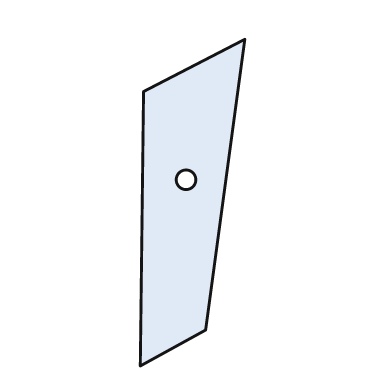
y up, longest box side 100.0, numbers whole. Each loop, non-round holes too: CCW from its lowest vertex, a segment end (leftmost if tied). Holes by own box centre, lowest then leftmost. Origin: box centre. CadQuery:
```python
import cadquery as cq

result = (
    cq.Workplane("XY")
    .moveTo(-16.0, -50.0)
    .lineTo(4.0, -39.0)
    .lineTo(16.0, 50.0)
    .lineTo(-15.0, 34.0)
    .close()
    .moveTo(-2.0, 7.0)
    .circle(3.0)
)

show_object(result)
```